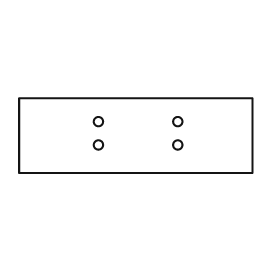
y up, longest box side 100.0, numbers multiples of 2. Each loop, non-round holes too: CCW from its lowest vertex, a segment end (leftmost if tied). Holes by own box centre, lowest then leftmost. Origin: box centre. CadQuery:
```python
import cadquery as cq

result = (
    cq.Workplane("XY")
    .moveTo(-50.0, -16.0)
    .lineTo(50.0, -16.0)
    .lineTo(50.0, 16.0)
    .lineTo(-50.0, 16.0)
    .close()
    .moveTo(-16.0, -4.0)
    .circle(2.0)
    .moveTo(18.0, -4.0)
    .circle(2.0)
    .moveTo(-16.0, 6.0)
    .circle(2.0)
    .moveTo(18.0, 6.0)
    .circle(2.0)
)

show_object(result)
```